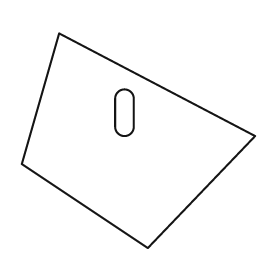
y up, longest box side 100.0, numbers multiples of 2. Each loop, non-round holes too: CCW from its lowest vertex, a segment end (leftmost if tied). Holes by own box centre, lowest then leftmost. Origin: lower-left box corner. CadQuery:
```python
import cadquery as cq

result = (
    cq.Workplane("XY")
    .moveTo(54.0, 0.0)
    .lineTo(100.0, 48.0)
    .lineTo(16.0, 92.0)
    .lineTo(0.0, 36.0)
    .close()
    .moveTo(40.0, 52.0)
    .threePointArc((44.0, 48.0), (48.0, 52.0))
    .lineTo(48.0, 64.0)
    .threePointArc((44.0, 68.0), (40.0, 64.0))
    .close()
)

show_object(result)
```